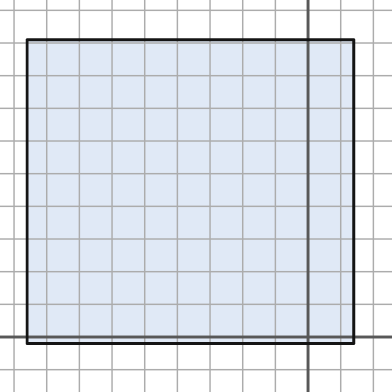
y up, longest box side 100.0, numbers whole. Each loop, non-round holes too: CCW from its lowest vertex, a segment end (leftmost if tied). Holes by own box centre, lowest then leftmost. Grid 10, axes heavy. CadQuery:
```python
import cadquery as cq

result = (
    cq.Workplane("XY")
    .moveTo(-86.0, -2.0)
    .lineTo(14.0, -2.0)
    .lineTo(14.0, 91.0)
    .lineTo(-86.0, 91.0)
    .close()
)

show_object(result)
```